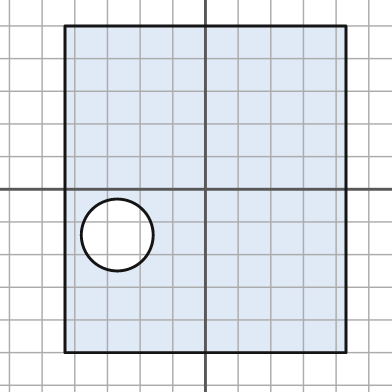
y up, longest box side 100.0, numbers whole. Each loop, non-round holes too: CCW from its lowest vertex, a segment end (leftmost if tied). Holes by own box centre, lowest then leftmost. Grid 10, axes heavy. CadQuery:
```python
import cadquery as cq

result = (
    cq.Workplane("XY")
    .moveTo(-43.0, -50.0)
    .lineTo(43.0, -50.0)
    .lineTo(43.0, 50.0)
    .lineTo(-43.0, 50.0)
    .close()
    .moveTo(-27.0, -14.0)
    .circle(11.0)
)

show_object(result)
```